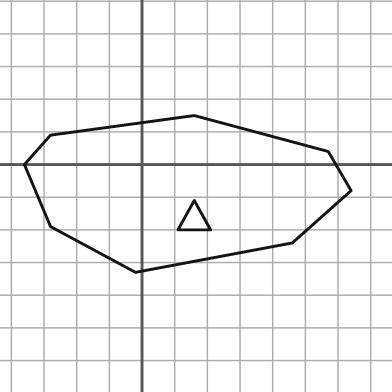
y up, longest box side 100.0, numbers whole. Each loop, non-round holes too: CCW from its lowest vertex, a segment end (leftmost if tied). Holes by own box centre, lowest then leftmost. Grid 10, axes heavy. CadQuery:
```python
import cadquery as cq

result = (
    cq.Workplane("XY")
    .moveTo(-2.0, -33.0)
    .lineTo(46.0, -24.0)
    .lineTo(64.0, -8.0)
    .lineTo(57.0, 4.0)
    .lineTo(16.0, 15.0)
    .lineTo(-28.0, 9.0)
    .lineTo(-36.0, 0.0)
    .lineTo(-28.0, -19.0)
    .close()
    .moveTo(11.0, -20.0)
    .lineTo(21.0, -20.0)
    .lineTo(16.0, -11.0)
    .close()
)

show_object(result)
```